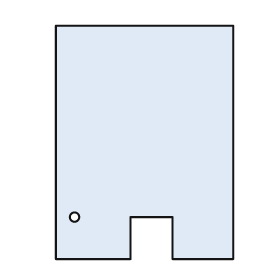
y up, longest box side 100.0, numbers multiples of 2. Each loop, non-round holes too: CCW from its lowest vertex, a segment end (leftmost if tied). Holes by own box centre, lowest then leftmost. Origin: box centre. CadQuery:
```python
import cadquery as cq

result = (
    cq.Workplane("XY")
    .moveTo(-38.0, -50.0)
    .lineTo(-6.0, -50.0)
    .lineTo(-6.0, -32.0)
    .lineTo(12.0, -32.0)
    .lineTo(12.0, -50.0)
    .lineTo(38.0, -50.0)
    .lineTo(38.0, 50.0)
    .lineTo(-38.0, 50.0)
    .close()
    .moveTo(-30.0, -32.0)
    .circle(2.0)
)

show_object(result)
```